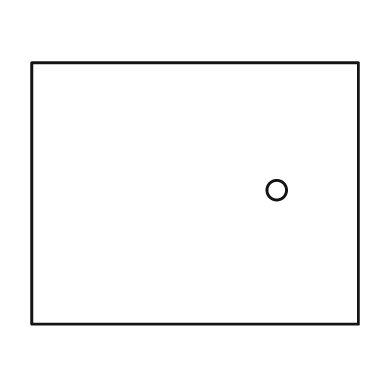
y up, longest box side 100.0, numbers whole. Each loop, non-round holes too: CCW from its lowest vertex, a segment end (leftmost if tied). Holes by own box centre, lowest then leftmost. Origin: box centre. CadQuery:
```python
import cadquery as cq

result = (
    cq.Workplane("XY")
    .moveTo(-50.0, -40.0)
    .lineTo(50.0, -40.0)
    .lineTo(50.0, 40.0)
    .lineTo(-50.0, 40.0)
    .close()
    .moveTo(25.0, 1.0)
    .circle(3.0)
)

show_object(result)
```